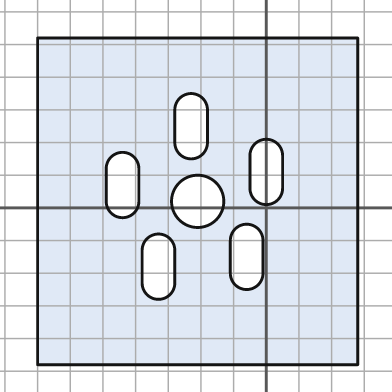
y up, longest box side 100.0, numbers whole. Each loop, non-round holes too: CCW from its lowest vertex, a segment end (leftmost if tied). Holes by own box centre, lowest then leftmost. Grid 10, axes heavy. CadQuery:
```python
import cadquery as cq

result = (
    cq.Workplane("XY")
    .moveTo(-70.0, -48.0)
    .lineTo(28.0, -48.0)
    .lineTo(28.0, 52.0)
    .lineTo(-70.0, 52.0)
    .close()
    .moveTo(-38.0, -23.0)
    .threePointArc((-33.0, -28.0), (-28.0, -23.0))
    .lineTo(-28.0, -13.0)
    .threePointArc((-33.0, -8.0), (-38.0, -13.0))
    .close()
    .moveTo(-11.0, -20.0)
    .threePointArc((-6.0, -25.0), (-1.0, -20.0))
    .lineTo(-1.0, -10.0)
    .threePointArc((-6.0, -5.0), (-11.0, -10.0))
    .close()
    .moveTo(-21.0, 2.0)
    .circle(8.0)
    .moveTo(-49.0, 2.0)
    .threePointArc((-44.0, -3.0), (-39.0, 2.0))
    .lineTo(-39.0, 12.0)
    .threePointArc((-44.0, 17.0), (-49.0, 12.0))
    .close()
    .moveTo(-5.0, 6.0)
    .threePointArc((0.0, 1.0), (5.0, 6.0))
    .lineTo(5.0, 16.0)
    .threePointArc((0.0, 21.0), (-5.0, 16.0))
    .close()
    .moveTo(-28.0, 20.0)
    .threePointArc((-23.0, 15.0), (-18.0, 20.0))
    .lineTo(-18.0, 30.0)
    .threePointArc((-23.0, 35.0), (-28.0, 30.0))
    .close()
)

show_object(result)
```